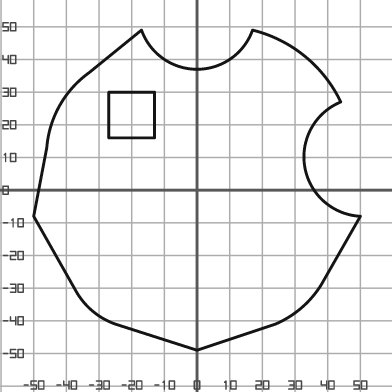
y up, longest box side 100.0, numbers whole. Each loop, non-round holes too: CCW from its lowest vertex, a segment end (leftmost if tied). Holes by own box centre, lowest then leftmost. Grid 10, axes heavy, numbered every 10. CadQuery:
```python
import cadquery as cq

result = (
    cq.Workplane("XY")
    .moveTo(0.0, -49.0)
    .lineTo(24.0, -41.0)
    .threePointArc((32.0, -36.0), (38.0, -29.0))
    .lineTo(50.0, -8.0)
    .threePointArc((33.0, 7.0), (44.0, 27.0))
    .threePointArc((33.0, 41.0), (17.0, 49.0))
    .threePointArc((0.0, 37.0), (-17.0, 49.0))
    .lineTo(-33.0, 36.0)
    .threePointArc((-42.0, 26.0), (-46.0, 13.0))
    .lineTo(-50.0, -8.0)
    .lineTo(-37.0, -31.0)
    .threePointArc((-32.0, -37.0), (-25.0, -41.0))
    .close()
    .moveTo(-27.0, 16.0)
    .lineTo(-13.0, 16.0)
    .lineTo(-13.0, 30.0)
    .lineTo(-27.0, 30.0)
    .close()
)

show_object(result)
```